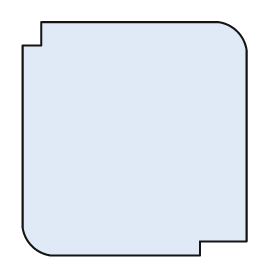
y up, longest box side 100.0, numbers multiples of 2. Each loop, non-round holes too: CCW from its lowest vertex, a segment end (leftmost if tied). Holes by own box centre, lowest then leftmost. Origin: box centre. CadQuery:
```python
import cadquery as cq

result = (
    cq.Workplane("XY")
    .moveTo(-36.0, -50.0)
    .lineTo(28.0, -50.0)
    .lineTo(28.0, -44.0)
    .lineTo(48.0, -44.0)
    .lineTo(48.0, 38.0)
    .threePointArc((44.0, 46.0), (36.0, 50.0))
    .lineTo(-40.0, 50.0)
    .lineTo(-40.0, 40.0)
    .lineTo(-48.0, 40.0)
    .lineTo(-48.0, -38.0)
    .threePointArc((-44.0, -46.0), (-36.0, -50.0))
    .close()
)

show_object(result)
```